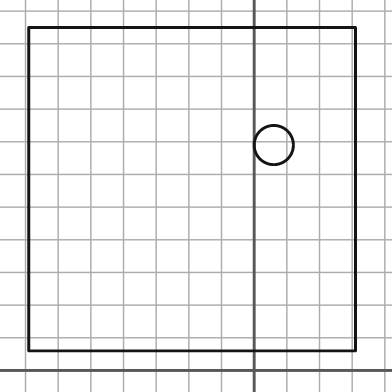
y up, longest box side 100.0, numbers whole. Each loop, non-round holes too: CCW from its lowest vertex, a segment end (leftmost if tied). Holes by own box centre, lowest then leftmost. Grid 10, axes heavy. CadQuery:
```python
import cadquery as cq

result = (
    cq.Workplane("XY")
    .moveTo(-69.0, 6.0)
    .lineTo(31.0, 6.0)
    .lineTo(31.0, 105.0)
    .lineTo(-69.0, 105.0)
    .close()
    .moveTo(6.0, 69.0)
    .circle(6.0)
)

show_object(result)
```